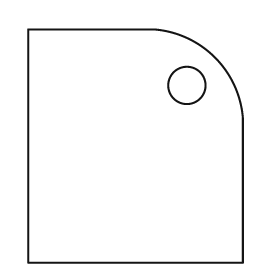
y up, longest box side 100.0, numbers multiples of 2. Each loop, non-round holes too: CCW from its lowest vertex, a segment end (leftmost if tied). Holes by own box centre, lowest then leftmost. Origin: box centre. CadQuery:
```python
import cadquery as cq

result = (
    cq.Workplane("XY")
    .moveTo(-46.0, -50.0)
    .lineTo(46.0, -50.0)
    .lineTo(46.0, 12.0)
    .threePointArc((34.0, 38.0), (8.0, 50.0))
    .lineTo(-46.0, 50.0)
    .close()
    .moveTo(22.0, 26.0)
    .circle(8.0)
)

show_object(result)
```